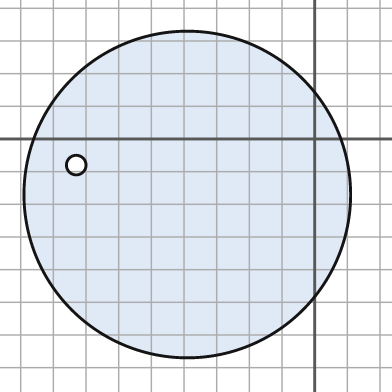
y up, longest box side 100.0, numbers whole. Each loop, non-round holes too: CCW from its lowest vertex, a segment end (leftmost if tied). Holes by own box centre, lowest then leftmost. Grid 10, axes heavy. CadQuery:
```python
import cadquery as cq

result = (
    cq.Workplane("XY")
    .moveTo(-39.0, -17.0)
    .circle(50.0)
    .moveTo(-73.0, -8.0)
    .circle(3.0)
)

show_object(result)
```